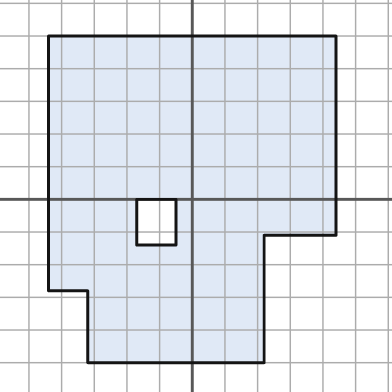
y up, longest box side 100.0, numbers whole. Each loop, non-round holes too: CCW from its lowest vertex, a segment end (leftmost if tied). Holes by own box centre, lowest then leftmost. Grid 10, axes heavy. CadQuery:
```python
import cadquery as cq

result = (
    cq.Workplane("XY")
    .moveTo(-32.0, -50.0)
    .lineTo(22.0, -50.0)
    .lineTo(22.0, -11.0)
    .lineTo(44.0, -11.0)
    .lineTo(44.0, 50.0)
    .lineTo(-44.0, 50.0)
    .lineTo(-44.0, -28.0)
    .lineTo(-32.0, -28.0)
    .close()
    .moveTo(-17.0, -14.0)
    .lineTo(-5.0, -14.0)
    .lineTo(-5.0, 0.0)
    .lineTo(-17.0, 0.0)
    .close()
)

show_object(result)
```